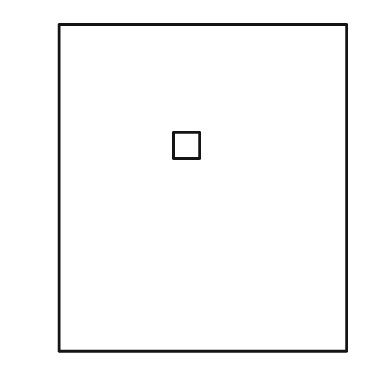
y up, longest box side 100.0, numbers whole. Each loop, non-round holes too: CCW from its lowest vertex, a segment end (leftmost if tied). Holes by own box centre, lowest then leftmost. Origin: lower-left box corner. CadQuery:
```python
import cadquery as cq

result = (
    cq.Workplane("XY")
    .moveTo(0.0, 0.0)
    .lineTo(88.0, 0.0)
    .lineTo(88.0, 100.0)
    .lineTo(0.0, 100.0)
    .close()
    .moveTo(35.0, 59.0)
    .lineTo(43.0, 59.0)
    .lineTo(43.0, 67.0)
    .lineTo(35.0, 67.0)
    .close()
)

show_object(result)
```